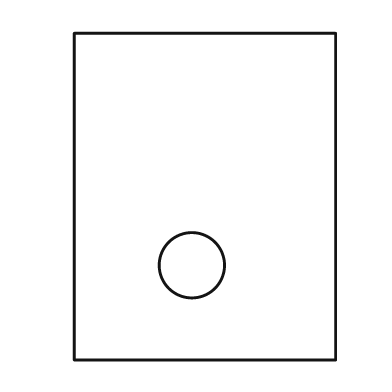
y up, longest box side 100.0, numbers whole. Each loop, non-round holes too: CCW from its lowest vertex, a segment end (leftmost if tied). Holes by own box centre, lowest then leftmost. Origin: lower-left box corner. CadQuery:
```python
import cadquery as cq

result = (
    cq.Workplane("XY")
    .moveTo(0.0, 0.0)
    .lineTo(80.0, 0.0)
    .lineTo(80.0, 100.0)
    .lineTo(0.0, 100.0)
    .close()
    .moveTo(36.0, 29.0)
    .circle(10.0)
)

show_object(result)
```